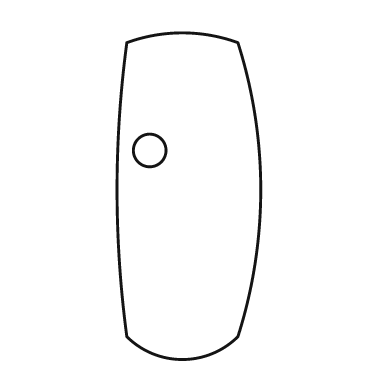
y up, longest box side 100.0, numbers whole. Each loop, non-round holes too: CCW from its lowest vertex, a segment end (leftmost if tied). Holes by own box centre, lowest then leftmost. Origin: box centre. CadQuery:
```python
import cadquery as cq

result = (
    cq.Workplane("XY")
    .moveTo(-19.0, -43.0)
    .threePointArc((-2.0, -50.0), (15.0, -43.0))
    .threePointArc((22.0, 2.0), (15.0, 47.0))
    .threePointArc((-2.0, 50.0), (-19.0, 47.0))
    .threePointArc((-22.0, 2.0), (-19.0, -43.0))
    .close()
    .moveTo(-12.0, 14.0)
    .circle(5.0)
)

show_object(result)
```